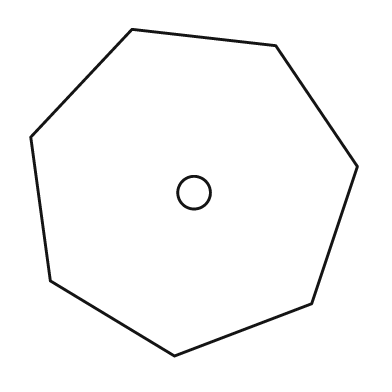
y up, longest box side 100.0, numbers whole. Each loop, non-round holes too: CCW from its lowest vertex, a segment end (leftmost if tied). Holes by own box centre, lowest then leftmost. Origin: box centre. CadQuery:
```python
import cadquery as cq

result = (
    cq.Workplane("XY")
    .moveTo(-6.0, -50.0)
    .lineTo(36.0, -34.0)
    .lineTo(50.0, 8.0)
    .lineTo(25.0, 45.0)
    .lineTo(-19.0, 50.0)
    .lineTo(-50.0, 17.0)
    .lineTo(-44.0, -27.0)
    .close()
    .moveTo(0.0, 0.0)
    .circle(5.0)
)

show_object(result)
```